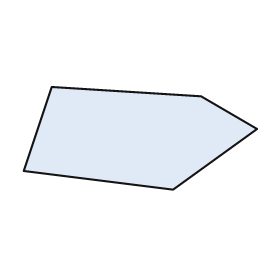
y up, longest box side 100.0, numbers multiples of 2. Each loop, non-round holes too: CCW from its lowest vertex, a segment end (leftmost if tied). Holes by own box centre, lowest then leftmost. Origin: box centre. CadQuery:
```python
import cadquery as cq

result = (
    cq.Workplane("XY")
    .moveTo(14.0, -22.0)
    .lineTo(50.0, 4.0)
    .lineTo(26.0, 18.0)
    .lineTo(-38.0, 22.0)
    .lineTo(-50.0, -14.0)
    .close()
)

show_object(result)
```